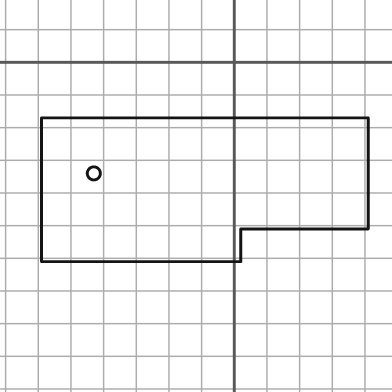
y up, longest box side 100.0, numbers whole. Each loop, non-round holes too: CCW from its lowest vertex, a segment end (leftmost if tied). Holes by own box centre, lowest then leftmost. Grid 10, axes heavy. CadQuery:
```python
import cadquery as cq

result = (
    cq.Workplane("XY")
    .moveTo(-59.0, -61.0)
    .lineTo(2.0, -61.0)
    .lineTo(2.0, -51.0)
    .lineTo(41.0, -51.0)
    .lineTo(41.0, -17.0)
    .lineTo(-59.0, -17.0)
    .close()
    .moveTo(-43.0, -34.0)
    .circle(2.0)
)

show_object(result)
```